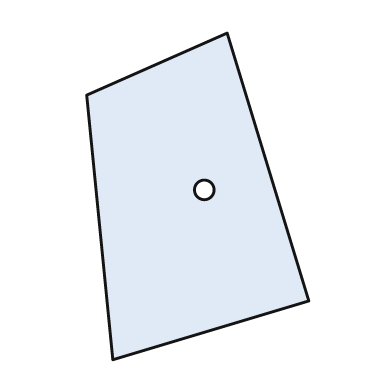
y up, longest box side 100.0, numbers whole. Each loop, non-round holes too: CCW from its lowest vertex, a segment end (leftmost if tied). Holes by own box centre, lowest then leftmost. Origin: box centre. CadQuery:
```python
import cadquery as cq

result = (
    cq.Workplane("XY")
    .moveTo(-26.0, -50.0)
    .lineTo(34.0, -32.0)
    .lineTo(9.0, 50.0)
    .lineTo(-34.0, 31.0)
    .close()
    .moveTo(2.0, 2.0)
    .circle(3.0)
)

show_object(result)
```